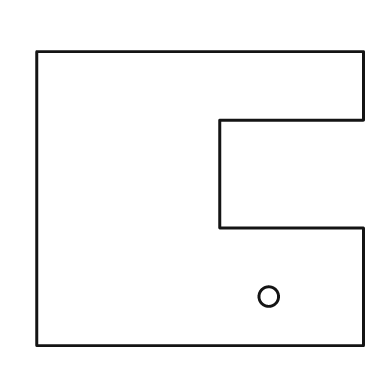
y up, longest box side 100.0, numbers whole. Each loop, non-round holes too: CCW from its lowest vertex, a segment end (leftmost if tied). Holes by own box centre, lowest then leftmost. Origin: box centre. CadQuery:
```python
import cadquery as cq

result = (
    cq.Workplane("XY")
    .moveTo(-50.0, -45.0)
    .lineTo(50.0, -45.0)
    .lineTo(50.0, -9.0)
    .lineTo(6.0, -9.0)
    .lineTo(6.0, 24.0)
    .lineTo(50.0, 24.0)
    .lineTo(50.0, 45.0)
    .lineTo(-50.0, 45.0)
    .close()
    .moveTo(21.0, -30.0)
    .circle(3.0)
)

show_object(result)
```